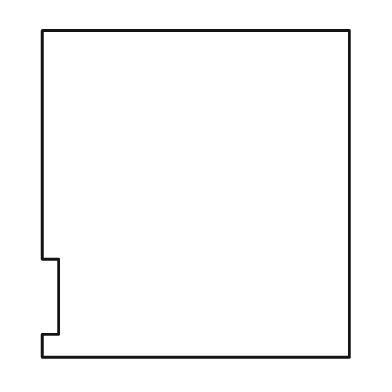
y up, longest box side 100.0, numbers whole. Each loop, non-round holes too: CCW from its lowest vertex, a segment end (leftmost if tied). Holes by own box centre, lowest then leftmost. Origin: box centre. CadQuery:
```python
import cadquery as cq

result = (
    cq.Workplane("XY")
    .moveTo(-47.0, -50.0)
    .lineTo(47.0, -50.0)
    .lineTo(47.0, 50.0)
    .lineTo(-47.0, 50.0)
    .lineTo(-47.0, -20.0)
    .lineTo(-42.0, -20.0)
    .lineTo(-42.0, -43.0)
    .lineTo(-47.0, -43.0)
    .close()
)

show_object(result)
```